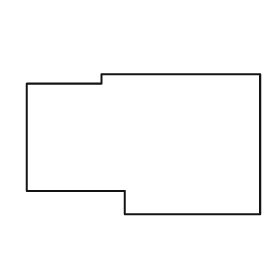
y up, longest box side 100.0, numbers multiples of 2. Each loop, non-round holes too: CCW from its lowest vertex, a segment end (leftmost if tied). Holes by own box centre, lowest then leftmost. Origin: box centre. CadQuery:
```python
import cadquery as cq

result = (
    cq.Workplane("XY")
    .moveTo(-8.0, -30.0)
    .lineTo(50.0, -30.0)
    .lineTo(50.0, 30.0)
    .lineTo(-18.0, 30.0)
    .lineTo(-18.0, 26.0)
    .lineTo(-50.0, 26.0)
    .lineTo(-50.0, -20.0)
    .lineTo(-8.0, -20.0)
    .close()
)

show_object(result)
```